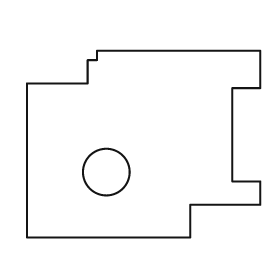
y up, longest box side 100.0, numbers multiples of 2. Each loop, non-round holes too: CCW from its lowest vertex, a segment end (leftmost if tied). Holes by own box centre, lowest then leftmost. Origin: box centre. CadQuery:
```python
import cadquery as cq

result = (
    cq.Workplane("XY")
    .moveTo(-50.0, -40.0)
    .lineTo(20.0, -40.0)
    .lineTo(20.0, -26.0)
    .lineTo(50.0, -26.0)
    .lineTo(50.0, -16.0)
    .lineTo(38.0, -16.0)
    .lineTo(38.0, 24.0)
    .lineTo(50.0, 24.0)
    .lineTo(50.0, 40.0)
    .lineTo(-20.0, 40.0)
    .lineTo(-20.0, 36.0)
    .lineTo(-24.0, 36.0)
    .lineTo(-24.0, 26.0)
    .lineTo(-50.0, 26.0)
    .close()
    .moveTo(-16.0, -12.0)
    .circle(10.0)
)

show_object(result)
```